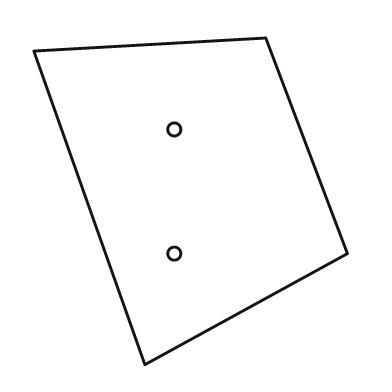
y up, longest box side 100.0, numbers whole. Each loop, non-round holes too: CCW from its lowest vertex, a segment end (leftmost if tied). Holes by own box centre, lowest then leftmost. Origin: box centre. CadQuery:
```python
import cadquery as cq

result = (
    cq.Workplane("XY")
    .moveTo(-14.0, -50.0)
    .lineTo(48.0, -16.0)
    .lineTo(23.0, 50.0)
    .lineTo(-48.0, 46.0)
    .close()
    .moveTo(-5.0, -16.0)
    .circle(2.0)
    .moveTo(-5.0, 22.0)
    .circle(2.0)
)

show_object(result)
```